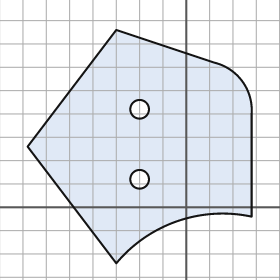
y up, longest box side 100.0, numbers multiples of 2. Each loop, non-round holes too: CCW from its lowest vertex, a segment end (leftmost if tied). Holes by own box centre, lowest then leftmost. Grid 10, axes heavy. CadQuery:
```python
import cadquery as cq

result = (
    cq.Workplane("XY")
    .moveTo(-30.0, -24.0)
    .threePointArc((-4.0, -6.0), (28.0, -4.0))
    .lineTo(28.0, 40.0)
    .threePointArc((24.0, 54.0), (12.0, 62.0))
    .lineTo(-30.0, 76.0)
    .lineTo(-68.0, 26.0)
    .close()
    .moveTo(-20.0, 12.0)
    .circle(4.0)
    .moveTo(-20.0, 42.0)
    .circle(4.0)
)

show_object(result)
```